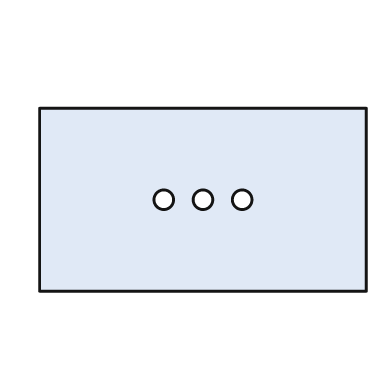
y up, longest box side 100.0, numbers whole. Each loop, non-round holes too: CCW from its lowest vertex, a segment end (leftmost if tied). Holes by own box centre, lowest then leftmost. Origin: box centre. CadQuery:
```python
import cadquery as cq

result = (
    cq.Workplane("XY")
    .moveTo(-50.0, -28.0)
    .lineTo(50.0, -28.0)
    .lineTo(50.0, 28.0)
    .lineTo(-50.0, 28.0)
    .close()
    .moveTo(-12.0, 0.0)
    .circle(3.0)
    .moveTo(0.0, 0.0)
    .circle(3.0)
    .moveTo(12.0, 0.0)
    .circle(3.0)
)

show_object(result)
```